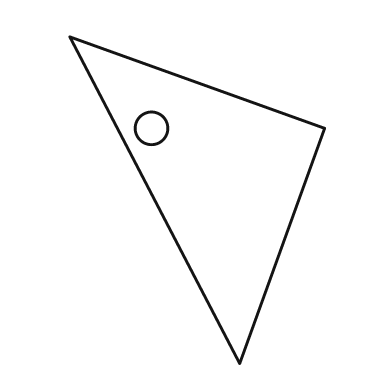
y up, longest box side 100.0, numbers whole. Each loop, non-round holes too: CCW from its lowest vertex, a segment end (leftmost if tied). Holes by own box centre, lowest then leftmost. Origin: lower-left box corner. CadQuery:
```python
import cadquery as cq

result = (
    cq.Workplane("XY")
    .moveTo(52.0, 0.0)
    .lineTo(78.0, 72.0)
    .lineTo(0.0, 100.0)
    .close()
    .moveTo(25.0, 72.0)
    .circle(5.0)
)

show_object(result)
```